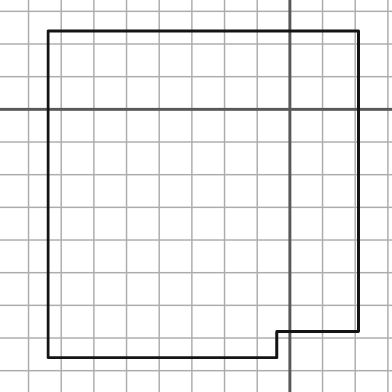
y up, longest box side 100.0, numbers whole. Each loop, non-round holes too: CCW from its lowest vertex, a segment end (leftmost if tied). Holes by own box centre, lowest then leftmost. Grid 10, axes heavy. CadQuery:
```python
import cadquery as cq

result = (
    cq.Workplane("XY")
    .moveTo(-74.0, -76.0)
    .lineTo(-4.0, -76.0)
    .lineTo(-4.0, -68.0)
    .lineTo(21.0, -68.0)
    .lineTo(21.0, 24.0)
    .lineTo(-74.0, 24.0)
    .close()
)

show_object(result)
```